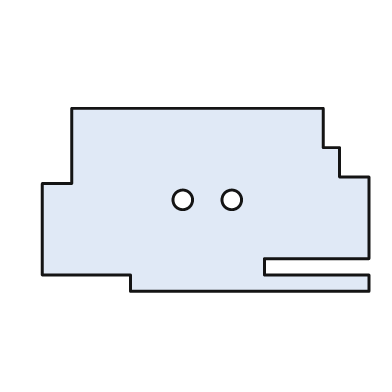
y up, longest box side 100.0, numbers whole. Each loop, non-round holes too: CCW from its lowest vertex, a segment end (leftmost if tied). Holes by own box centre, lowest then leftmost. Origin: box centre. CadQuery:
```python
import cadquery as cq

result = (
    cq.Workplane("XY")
    .moveTo(-23.0, -28.0)
    .lineTo(50.0, -28.0)
    .lineTo(50.0, -23.0)
    .lineTo(18.0, -23.0)
    .lineTo(18.0, -18.0)
    .lineTo(50.0, -18.0)
    .lineTo(50.0, 7.0)
    .lineTo(41.0, 7.0)
    .lineTo(41.0, 16.0)
    .lineTo(36.0, 16.0)
    .lineTo(36.0, 28.0)
    .lineTo(-41.0, 28.0)
    .lineTo(-41.0, 5.0)
    .lineTo(-50.0, 5.0)
    .lineTo(-50.0, -23.0)
    .lineTo(-23.0, -23.0)
    .close()
    .moveTo(-7.0, 0.0)
    .circle(3.0)
    .moveTo(8.0, 0.0)
    .circle(3.0)
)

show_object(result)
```